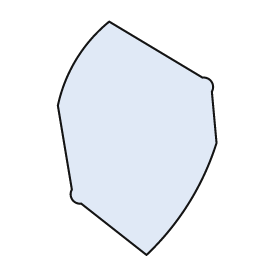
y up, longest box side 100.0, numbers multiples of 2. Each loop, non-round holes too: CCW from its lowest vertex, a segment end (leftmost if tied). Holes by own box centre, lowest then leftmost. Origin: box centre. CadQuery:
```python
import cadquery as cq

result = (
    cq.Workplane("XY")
    .moveTo(4.0, -50.0)
    .threePointArc((22.0, -28.0), (34.0, -2.0))
    .lineTo(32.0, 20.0)
    .threePointArc((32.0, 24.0), (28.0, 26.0))
    .lineTo(-12.0, 50.0)
    .threePointArc((-26.0, 34.0), (-34.0, 14.0))
    .lineTo(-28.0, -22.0)
    .threePointArc((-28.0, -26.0), (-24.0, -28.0))
    .close()
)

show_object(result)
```